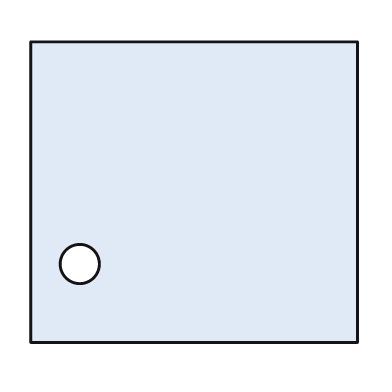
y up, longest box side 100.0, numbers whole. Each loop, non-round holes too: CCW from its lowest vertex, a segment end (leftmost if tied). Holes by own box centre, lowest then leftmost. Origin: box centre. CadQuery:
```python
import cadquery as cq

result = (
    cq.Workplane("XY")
    .moveTo(-50.0, -46.0)
    .lineTo(50.0, -46.0)
    .lineTo(50.0, 46.0)
    .lineTo(-50.0, 46.0)
    .close()
    .moveTo(-35.0, -22.0)
    .circle(6.0)
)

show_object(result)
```